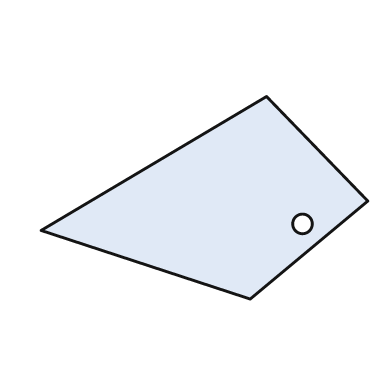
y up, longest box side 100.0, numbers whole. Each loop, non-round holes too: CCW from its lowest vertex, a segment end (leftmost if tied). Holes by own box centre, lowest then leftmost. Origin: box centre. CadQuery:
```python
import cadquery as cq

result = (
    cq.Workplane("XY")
    .moveTo(14.0, -31.0)
    .lineTo(50.0, -1.0)
    .lineTo(19.0, 31.0)
    .lineTo(-50.0, -10.0)
    .close()
    .moveTo(30.0, -8.0)
    .circle(3.0)
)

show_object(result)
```